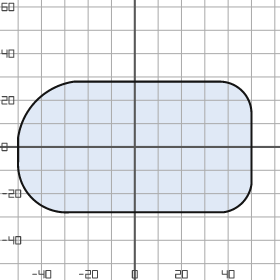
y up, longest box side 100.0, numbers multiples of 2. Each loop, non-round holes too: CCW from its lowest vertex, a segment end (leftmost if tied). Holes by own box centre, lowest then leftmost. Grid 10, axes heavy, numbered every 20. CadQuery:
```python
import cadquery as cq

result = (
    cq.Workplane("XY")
    .moveTo(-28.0, -28.0)
    .lineTo(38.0, -28.0)
    .threePointArc((46.0, -24.0), (50.0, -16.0))
    .lineTo(50.0, 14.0)
    .threePointArc((46.0, 24.0), (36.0, 28.0))
    .lineTo(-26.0, 28.0)
    .threePointArc((-42.0, 20.0), (-50.0, 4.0))
    .lineTo(-50.0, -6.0)
    .threePointArc((-44.0, -22.0), (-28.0, -28.0))
    .close()
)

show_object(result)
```